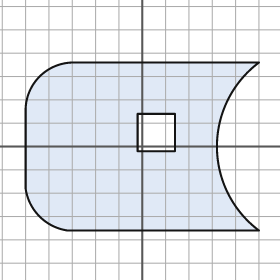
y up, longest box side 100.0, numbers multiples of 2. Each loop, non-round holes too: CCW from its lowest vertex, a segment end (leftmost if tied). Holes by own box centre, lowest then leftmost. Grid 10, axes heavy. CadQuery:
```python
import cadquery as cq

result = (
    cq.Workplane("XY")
    .moveTo(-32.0, -36.0)
    .lineTo(50.0, -36.0)
    .threePointArc((32.0, 0.0), (50.0, 36.0))
    .lineTo(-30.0, 36.0)
    .threePointArc((-44.0, 30.0), (-50.0, 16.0))
    .lineTo(-50.0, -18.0)
    .threePointArc((-44.0, -30.0), (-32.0, -36.0))
    .close()
    .moveTo(-2.0, -2.0)
    .lineTo(14.0, -2.0)
    .lineTo(14.0, 14.0)
    .lineTo(-2.0, 14.0)
    .close()
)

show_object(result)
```